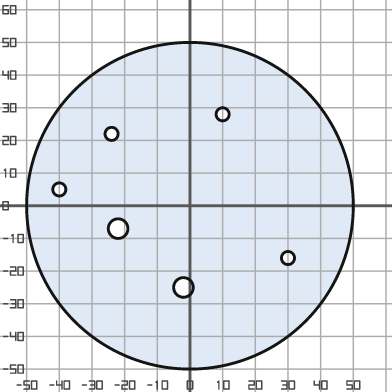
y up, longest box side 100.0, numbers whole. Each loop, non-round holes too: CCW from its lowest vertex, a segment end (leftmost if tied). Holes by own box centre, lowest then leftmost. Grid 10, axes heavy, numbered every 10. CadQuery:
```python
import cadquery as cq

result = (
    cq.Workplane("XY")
    .moveTo(0.0, 0.0)
    .circle(50.0)
    .moveTo(-2.0, -25.0)
    .circle(3.0)
    .moveTo(30.0, -16.0)
    .circle(2.0)
    .moveTo(-22.0, -7.0)
    .circle(3.0)
    .moveTo(-40.0, 5.0)
    .circle(2.0)
    .moveTo(-24.0, 22.0)
    .circle(2.0)
    .moveTo(10.0, 28.0)
    .circle(2.0)
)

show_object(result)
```